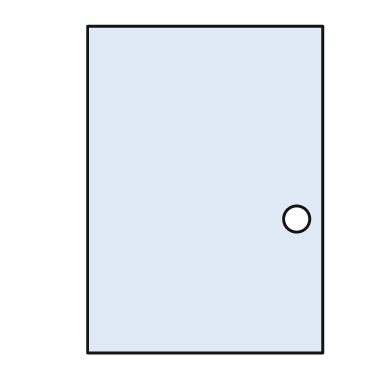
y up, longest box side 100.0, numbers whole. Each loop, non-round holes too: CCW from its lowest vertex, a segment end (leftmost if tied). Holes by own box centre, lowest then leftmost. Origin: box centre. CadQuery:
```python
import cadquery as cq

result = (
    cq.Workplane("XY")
    .moveTo(-36.0, -50.0)
    .lineTo(36.0, -50.0)
    .lineTo(36.0, 50.0)
    .lineTo(-36.0, 50.0)
    .close()
    .moveTo(28.0, -9.0)
    .circle(4.0)
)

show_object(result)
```